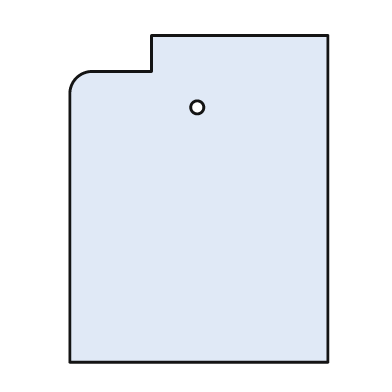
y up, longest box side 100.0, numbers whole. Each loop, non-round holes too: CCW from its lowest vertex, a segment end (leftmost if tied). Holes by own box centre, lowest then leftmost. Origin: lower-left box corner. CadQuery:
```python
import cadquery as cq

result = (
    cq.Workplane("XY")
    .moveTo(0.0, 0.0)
    .lineTo(79.0, 0.0)
    .lineTo(79.0, 100.0)
    .lineTo(25.0, 100.0)
    .lineTo(25.0, 89.0)
    .lineTo(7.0, 89.0)
    .threePointArc((2.0, 87.0), (0.0, 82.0))
    .close()
    .moveTo(39.0, 78.0)
    .circle(2.0)
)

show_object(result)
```